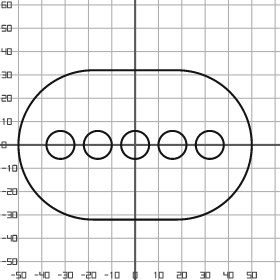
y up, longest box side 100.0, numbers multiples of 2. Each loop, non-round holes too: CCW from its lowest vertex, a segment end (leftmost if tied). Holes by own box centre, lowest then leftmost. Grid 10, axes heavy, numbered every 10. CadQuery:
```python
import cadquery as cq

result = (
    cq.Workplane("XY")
    .moveTo(-18.0, -32.0)
    .lineTo(18.0, -32.0)
    .threePointArc((50.0, 0.0), (18.0, 32.0))
    .lineTo(-18.0, 32.0)
    .threePointArc((-50.0, 0.0), (-18.0, -32.0))
    .close()
    .moveTo(-32.0, 0.0)
    .circle(6.0)
    .moveTo(-16.0, 0.0)
    .circle(6.0)
    .moveTo(0.0, 0.0)
    .circle(6.0)
    .moveTo(16.0, 0.0)
    .circle(6.0)
    .moveTo(32.0, 0.0)
    .circle(6.0)
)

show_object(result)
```